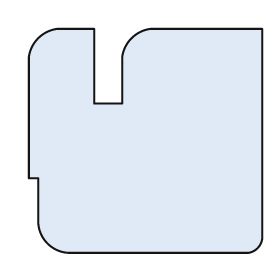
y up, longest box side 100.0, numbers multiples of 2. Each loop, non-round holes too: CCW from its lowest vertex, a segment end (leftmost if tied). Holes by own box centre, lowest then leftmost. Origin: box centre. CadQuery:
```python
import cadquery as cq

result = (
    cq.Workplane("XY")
    .moveTo(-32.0, -48.0)
    .lineTo(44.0, -48.0)
    .threePointArc((48.0, -46.0), (50.0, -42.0))
    .lineTo(50.0, 48.0)
    .lineTo(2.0, 48.0)
    .threePointArc((-6.0, 44.0), (-10.0, 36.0))
    .lineTo(-10.0, 16.0)
    .lineTo(-22.0, 16.0)
    .lineTo(-22.0, 48.0)
    .lineTo(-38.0, 48.0)
    .threePointArc((-46.0, 44.0), (-50.0, 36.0))
    .lineTo(-50.0, -16.0)
    .lineTo(-46.0, -16.0)
    .lineTo(-46.0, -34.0)
    .threePointArc((-42.0, -44.0), (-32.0, -48.0))
    .close()
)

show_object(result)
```